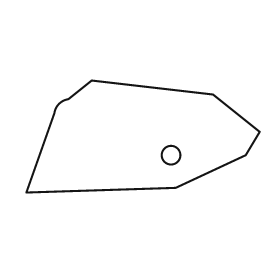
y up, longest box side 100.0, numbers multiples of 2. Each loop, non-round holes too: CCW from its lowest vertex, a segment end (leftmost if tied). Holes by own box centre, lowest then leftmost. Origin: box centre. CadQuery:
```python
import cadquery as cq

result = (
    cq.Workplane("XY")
    .moveTo(-50.0, -24.0)
    .lineTo(14.0, -22.0)
    .lineTo(44.0, -8.0)
    .lineTo(50.0, 2.0)
    .lineTo(30.0, 18.0)
    .lineTo(-22.0, 24.0)
    .lineTo(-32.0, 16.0)
    .threePointArc((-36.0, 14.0), (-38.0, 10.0))
    .close()
    .moveTo(12.0, -8.0)
    .circle(4.0)
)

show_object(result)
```